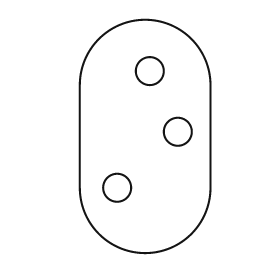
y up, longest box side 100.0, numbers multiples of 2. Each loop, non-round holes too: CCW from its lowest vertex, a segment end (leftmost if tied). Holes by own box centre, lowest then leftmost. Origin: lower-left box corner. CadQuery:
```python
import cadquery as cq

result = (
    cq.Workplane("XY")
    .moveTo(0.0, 28.0)
    .threePointArc((28.0, 0.0), (56.0, 28.0))
    .lineTo(56.0, 72.0)
    .threePointArc((28.0, 100.0), (0.0, 72.0))
    .close()
    .moveTo(16.0, 28.0)
    .circle(6.0)
    .moveTo(42.0, 52.0)
    .circle(6.0)
    .moveTo(30.0, 78.0)
    .circle(6.0)
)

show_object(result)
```